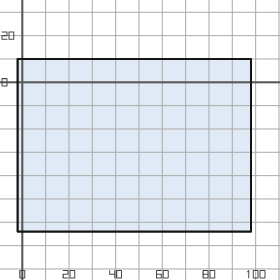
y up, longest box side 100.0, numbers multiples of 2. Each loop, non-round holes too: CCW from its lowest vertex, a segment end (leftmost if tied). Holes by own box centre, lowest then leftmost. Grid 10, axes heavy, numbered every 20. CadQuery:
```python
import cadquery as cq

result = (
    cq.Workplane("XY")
    .moveTo(-2.0, -64.0)
    .lineTo(98.0, -64.0)
    .lineTo(98.0, 10.0)
    .lineTo(-2.0, 10.0)
    .close()
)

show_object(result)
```